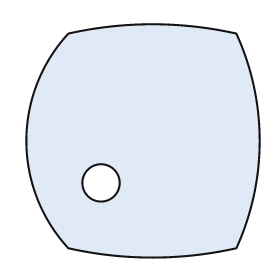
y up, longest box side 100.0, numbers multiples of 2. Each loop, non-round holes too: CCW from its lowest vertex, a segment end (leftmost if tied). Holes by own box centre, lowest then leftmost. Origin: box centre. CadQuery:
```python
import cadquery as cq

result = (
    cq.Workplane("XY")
    .moveTo(-32.0, -46.0)
    .threePointArc((4.0, -50.0), (40.0, -46.0))
    .threePointArc((50.0, 0.0), (40.0, 46.0))
    .threePointArc((4.0, 50.0), (-32.0, 46.0))
    .threePointArc((-50.0, 0.0), (-32.0, -46.0))
    .close()
    .moveTo(-18.0, -18.0)
    .circle(8.0)
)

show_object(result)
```